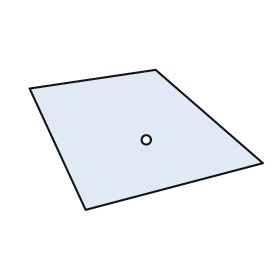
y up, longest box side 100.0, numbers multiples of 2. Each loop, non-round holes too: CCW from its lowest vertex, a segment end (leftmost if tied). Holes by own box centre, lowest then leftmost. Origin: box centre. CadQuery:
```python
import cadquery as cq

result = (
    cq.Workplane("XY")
    .moveTo(-26.0, -30.0)
    .lineTo(50.0, -10.0)
    .lineTo(4.0, 30.0)
    .lineTo(-50.0, 22.0)
    .close()
    .moveTo(0.0, 0.0)
    .circle(2.0)
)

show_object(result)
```